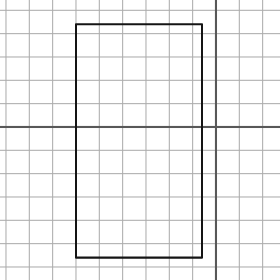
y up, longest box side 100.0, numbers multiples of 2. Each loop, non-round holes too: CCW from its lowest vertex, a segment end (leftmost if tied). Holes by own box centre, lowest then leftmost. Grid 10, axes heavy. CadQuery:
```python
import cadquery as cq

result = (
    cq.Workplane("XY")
    .moveTo(-60.0, -56.0)
    .lineTo(-6.0, -56.0)
    .lineTo(-6.0, 44.0)
    .lineTo(-60.0, 44.0)
    .close()
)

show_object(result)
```